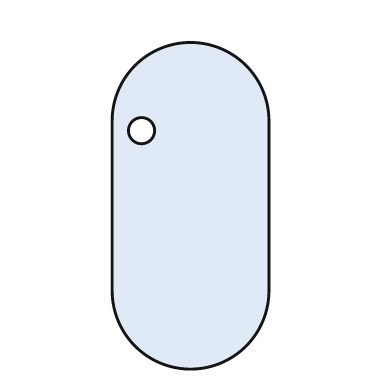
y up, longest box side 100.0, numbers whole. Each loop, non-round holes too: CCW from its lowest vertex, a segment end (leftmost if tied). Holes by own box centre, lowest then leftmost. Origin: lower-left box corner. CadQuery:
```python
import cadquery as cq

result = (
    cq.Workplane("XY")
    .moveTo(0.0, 24.0)
    .threePointArc((24.0, 0.0), (48.0, 24.0))
    .lineTo(48.0, 76.0)
    .threePointArc((24.0, 100.0), (0.0, 76.0))
    .close()
    .moveTo(9.0, 73.0)
    .circle(4.0)
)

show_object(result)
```